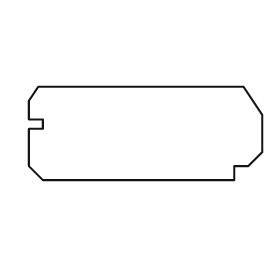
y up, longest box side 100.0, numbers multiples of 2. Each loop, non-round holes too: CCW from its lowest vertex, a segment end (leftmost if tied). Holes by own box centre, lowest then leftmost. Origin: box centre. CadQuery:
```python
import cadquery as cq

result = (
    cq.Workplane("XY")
    .moveTo(-44.0, -20.0)
    .lineTo(38.0, -20.0)
    .lineTo(38.0, -14.0)
    .lineTo(44.0, -14.0)
    .lineTo(50.0, -8.0)
    .lineTo(50.0, 8.0)
    .lineTo(42.0, 20.0)
    .lineTo(-46.0, 20.0)
    .lineTo(-50.0, 14.0)
    .lineTo(-50.0, 6.0)
    .lineTo(-44.0, 6.0)
    .lineTo(-44.0, 2.0)
    .lineTo(-50.0, 2.0)
    .lineTo(-50.0, -14.0)
    .close()
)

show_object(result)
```